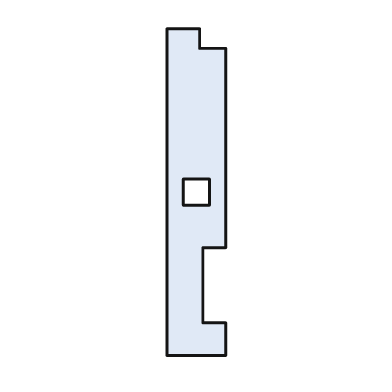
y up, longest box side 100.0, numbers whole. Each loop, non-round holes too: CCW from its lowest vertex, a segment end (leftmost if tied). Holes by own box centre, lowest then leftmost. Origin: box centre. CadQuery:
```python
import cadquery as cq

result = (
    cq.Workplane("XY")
    .moveTo(-9.0, -50.0)
    .lineTo(9.0, -50.0)
    .lineTo(9.0, -40.0)
    .lineTo(2.0, -40.0)
    .lineTo(2.0, -17.0)
    .lineTo(9.0, -17.0)
    .lineTo(9.0, 44.0)
    .lineTo(1.0, 44.0)
    .lineTo(1.0, 50.0)
    .lineTo(-9.0, 50.0)
    .close()
    .moveTo(-4.0, -4.0)
    .lineTo(4.0, -4.0)
    .lineTo(4.0, 4.0)
    .lineTo(-4.0, 4.0)
    .close()
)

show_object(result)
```